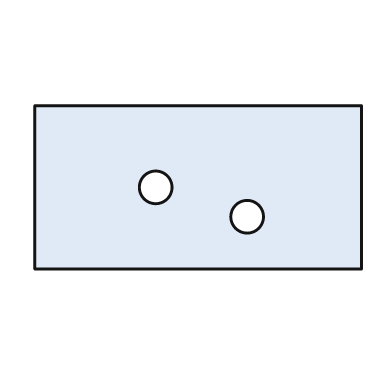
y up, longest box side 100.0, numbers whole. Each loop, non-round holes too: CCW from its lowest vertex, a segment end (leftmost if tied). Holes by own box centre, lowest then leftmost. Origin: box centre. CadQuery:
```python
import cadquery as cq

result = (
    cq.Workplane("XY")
    .moveTo(-50.0, -25.0)
    .lineTo(50.0, -25.0)
    .lineTo(50.0, 25.0)
    .lineTo(-50.0, 25.0)
    .close()
    .moveTo(15.0, -9.0)
    .circle(5.0)
    .moveTo(-13.0, 0.0)
    .circle(5.0)
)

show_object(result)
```